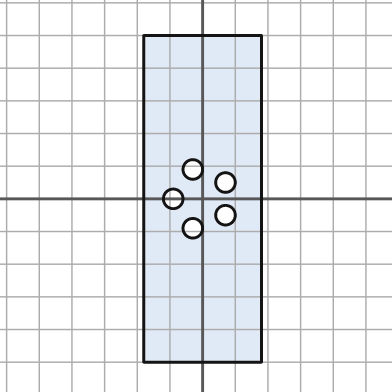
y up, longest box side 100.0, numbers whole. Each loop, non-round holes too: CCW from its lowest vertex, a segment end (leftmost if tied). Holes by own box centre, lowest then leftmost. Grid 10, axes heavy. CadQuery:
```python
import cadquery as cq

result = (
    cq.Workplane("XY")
    .moveTo(-18.0, -50.0)
    .lineTo(18.0, -50.0)
    .lineTo(18.0, 50.0)
    .lineTo(-18.0, 50.0)
    .close()
    .moveTo(-3.0, -9.0)
    .circle(3.0)
    .moveTo(7.0, -5.0)
    .circle(3.0)
    .moveTo(-9.0, 0.0)
    .circle(3.0)
    .moveTo(7.0, 5.0)
    .circle(3.0)
    .moveTo(-3.0, 9.0)
    .circle(3.0)
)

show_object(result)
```